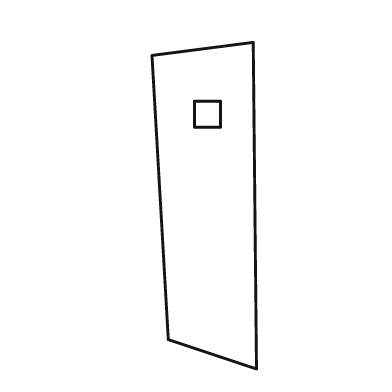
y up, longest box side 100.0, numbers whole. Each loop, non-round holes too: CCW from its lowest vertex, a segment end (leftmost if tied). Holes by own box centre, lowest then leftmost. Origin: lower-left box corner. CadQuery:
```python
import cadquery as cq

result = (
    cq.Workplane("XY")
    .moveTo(32.0, 0.0)
    .lineTo(31.0, 100.0)
    .lineTo(0.0, 96.0)
    .lineTo(5.0, 9.0)
    .close()
    .moveTo(13.0, 74.0)
    .lineTo(21.0, 74.0)
    .lineTo(21.0, 82.0)
    .lineTo(13.0, 82.0)
    .close()
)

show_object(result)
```